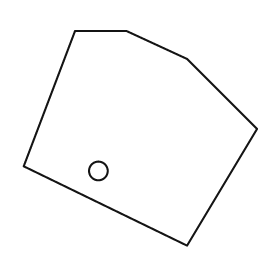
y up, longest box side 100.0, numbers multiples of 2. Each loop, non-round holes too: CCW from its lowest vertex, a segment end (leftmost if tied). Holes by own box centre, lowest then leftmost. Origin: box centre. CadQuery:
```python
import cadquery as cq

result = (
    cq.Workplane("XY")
    .moveTo(20.0, -46.0)
    .lineTo(50.0, 4.0)
    .lineTo(20.0, 34.0)
    .lineTo(-6.0, 46.0)
    .lineTo(-28.0, 46.0)
    .lineTo(-50.0, -12.0)
    .close()
    .moveTo(-18.0, -14.0)
    .circle(4.0)
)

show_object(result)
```